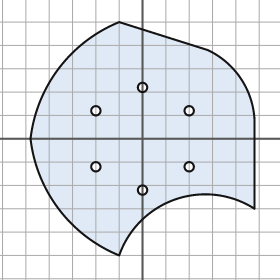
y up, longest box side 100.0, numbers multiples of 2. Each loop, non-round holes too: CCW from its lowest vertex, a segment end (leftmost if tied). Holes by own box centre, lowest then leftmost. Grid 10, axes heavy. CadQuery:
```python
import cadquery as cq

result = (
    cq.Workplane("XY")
    .moveTo(-10.0, -50.0)
    .threePointArc((14.0, -26.0), (48.0, -30.0))
    .lineTo(48.0, 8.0)
    .threePointArc((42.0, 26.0), (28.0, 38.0))
    .lineTo(-10.0, 50.0)
    .threePointArc((-36.0, 30.0), (-48.0, 0.0))
    .threePointArc((-36.0, -30.0), (-10.0, -50.0))
    .close()
    .moveTo(0.0, -22.0)
    .circle(2.0)
    .moveTo(-20.0, -12.0)
    .circle(2.0)
    .moveTo(20.0, -12.0)
    .circle(2.0)
    .moveTo(-20.0, 12.0)
    .circle(2.0)
    .moveTo(20.0, 12.0)
    .circle(2.0)
    .moveTo(0.0, 22.0)
    .circle(2.0)
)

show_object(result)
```